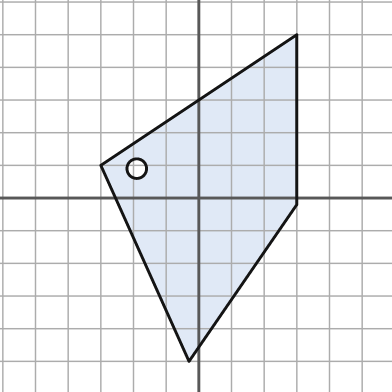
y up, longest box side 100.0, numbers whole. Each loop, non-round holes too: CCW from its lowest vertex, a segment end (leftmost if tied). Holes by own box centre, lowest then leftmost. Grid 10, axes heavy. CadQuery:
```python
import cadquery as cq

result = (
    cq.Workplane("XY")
    .moveTo(-3.0, -50.0)
    .lineTo(30.0, -2.0)
    .lineTo(30.0, 50.0)
    .lineTo(-30.0, 10.0)
    .close()
    .moveTo(-19.0, 9.0)
    .circle(3.0)
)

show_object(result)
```